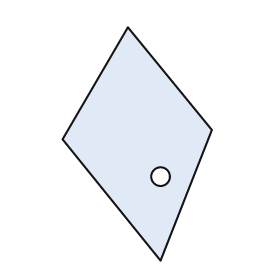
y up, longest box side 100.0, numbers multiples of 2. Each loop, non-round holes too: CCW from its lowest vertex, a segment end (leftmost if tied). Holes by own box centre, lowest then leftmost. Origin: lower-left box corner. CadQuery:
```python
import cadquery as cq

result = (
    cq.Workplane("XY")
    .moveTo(42.0, 0.0)
    .lineTo(64.0, 56.0)
    .lineTo(28.0, 100.0)
    .lineTo(0.0, 52.0)
    .close()
    .moveTo(42.0, 36.0)
    .circle(4.0)
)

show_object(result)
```